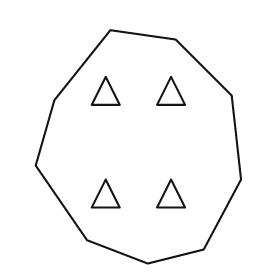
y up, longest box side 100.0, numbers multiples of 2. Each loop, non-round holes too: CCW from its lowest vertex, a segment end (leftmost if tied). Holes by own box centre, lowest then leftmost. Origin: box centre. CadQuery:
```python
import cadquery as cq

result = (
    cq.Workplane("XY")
    .moveTo(4.0, -50.0)
    .lineTo(28.0, -44.0)
    .lineTo(44.0, -14.0)
    .lineTo(40.0, 22.0)
    .lineTo(16.0, 46.0)
    .lineTo(-12.0, 50.0)
    .lineTo(-36.0, 20.0)
    .lineTo(-44.0, -8.0)
    .lineTo(-22.0, -40.0)
    .close()
    .moveTo(-20.0, -26.0)
    .lineTo(-8.0, -26.0)
    .lineTo(-14.0, -14.0)
    .close()
    .moveTo(8.0, -26.0)
    .lineTo(20.0, -26.0)
    .lineTo(14.0, -14.0)
    .close()
    .moveTo(-20.0, 18.0)
    .lineTo(-8.0, 18.0)
    .lineTo(-14.0, 30.0)
    .close()
    .moveTo(8.0, 18.0)
    .lineTo(20.0, 18.0)
    .lineTo(14.0, 30.0)
    .close()
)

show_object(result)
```